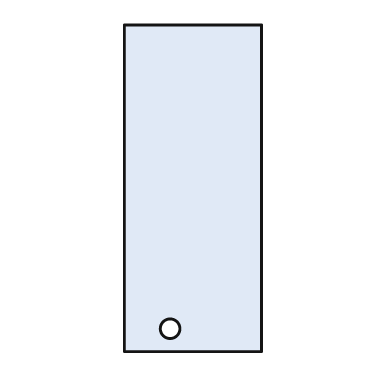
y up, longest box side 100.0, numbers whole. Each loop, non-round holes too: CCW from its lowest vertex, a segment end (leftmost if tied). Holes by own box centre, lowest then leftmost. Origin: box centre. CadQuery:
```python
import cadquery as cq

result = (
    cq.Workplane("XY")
    .moveTo(-21.0, -50.0)
    .lineTo(21.0, -50.0)
    .lineTo(21.0, 50.0)
    .lineTo(-21.0, 50.0)
    .close()
    .moveTo(-7.0, -43.0)
    .circle(3.0)
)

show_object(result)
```